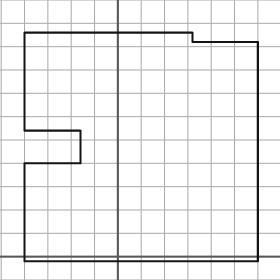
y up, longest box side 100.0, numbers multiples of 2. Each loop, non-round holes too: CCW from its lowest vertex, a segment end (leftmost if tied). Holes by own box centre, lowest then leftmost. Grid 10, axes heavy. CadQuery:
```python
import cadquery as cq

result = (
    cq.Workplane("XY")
    .moveTo(-40.0, -2.0)
    .lineTo(60.0, -2.0)
    .lineTo(60.0, 92.0)
    .lineTo(32.0, 92.0)
    .lineTo(32.0, 96.0)
    .lineTo(-40.0, 96.0)
    .lineTo(-40.0, 54.0)
    .lineTo(-16.0, 54.0)
    .lineTo(-16.0, 40.0)
    .lineTo(-40.0, 40.0)
    .close()
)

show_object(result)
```